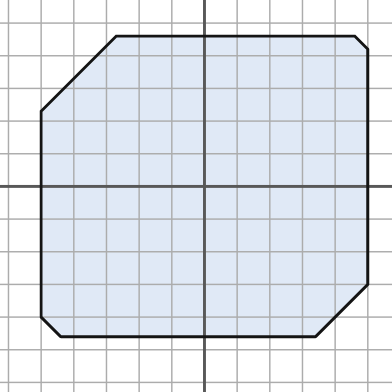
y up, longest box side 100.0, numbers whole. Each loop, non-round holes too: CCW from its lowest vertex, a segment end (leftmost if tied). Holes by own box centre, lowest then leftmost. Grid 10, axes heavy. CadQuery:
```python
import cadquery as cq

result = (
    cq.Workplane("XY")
    .moveTo(-44.0, -46.0)
    .lineTo(34.0, -46.0)
    .lineTo(50.0, -30.0)
    .lineTo(50.0, 42.0)
    .lineTo(46.0, 46.0)
    .lineTo(-27.0, 46.0)
    .lineTo(-50.0, 23.0)
    .lineTo(-50.0, -40.0)
    .close()
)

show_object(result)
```